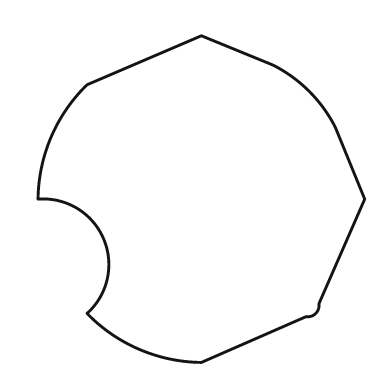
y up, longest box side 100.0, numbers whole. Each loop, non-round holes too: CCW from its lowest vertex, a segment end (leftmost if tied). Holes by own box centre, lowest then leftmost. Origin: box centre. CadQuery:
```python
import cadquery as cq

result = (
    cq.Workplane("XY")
    .moveTo(0.0, -50.0)
    .lineTo(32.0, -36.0)
    .threePointArc((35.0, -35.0), (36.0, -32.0))
    .lineTo(50.0, 0.0)
    .lineTo(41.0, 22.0)
    .threePointArc((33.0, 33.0), (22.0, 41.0))
    .lineTo(0.0, 50.0)
    .lineTo(-35.0, 35.0)
    .threePointArc((-46.0, 19.0), (-50.0, 0.0))
    .threePointArc((-30.0, -12.0), (-35.0, -35.0))
    .threePointArc((-19.0, -46.0), (0.0, -50.0))
    .close()
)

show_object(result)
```